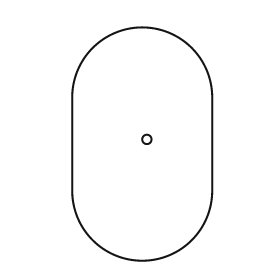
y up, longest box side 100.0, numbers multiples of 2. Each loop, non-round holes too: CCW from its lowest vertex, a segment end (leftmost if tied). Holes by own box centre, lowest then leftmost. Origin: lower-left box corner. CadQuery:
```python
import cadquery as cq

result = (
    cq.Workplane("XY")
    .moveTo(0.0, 30.0)
    .threePointArc((30.0, 0.0), (60.0, 30.0))
    .lineTo(60.0, 70.0)
    .threePointArc((30.0, 100.0), (0.0, 70.0))
    .close()
    .moveTo(32.0, 52.0)
    .circle(2.0)
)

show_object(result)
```